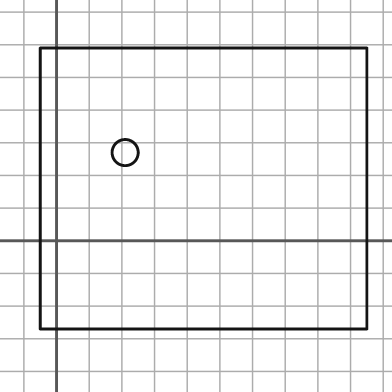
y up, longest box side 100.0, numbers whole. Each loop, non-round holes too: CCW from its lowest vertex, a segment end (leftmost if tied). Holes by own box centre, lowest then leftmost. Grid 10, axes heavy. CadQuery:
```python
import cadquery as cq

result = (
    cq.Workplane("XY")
    .moveTo(-5.0, -27.0)
    .lineTo(95.0, -27.0)
    .lineTo(95.0, 59.0)
    .lineTo(-5.0, 59.0)
    .close()
    .moveTo(21.0, 27.0)
    .circle(4.0)
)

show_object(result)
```